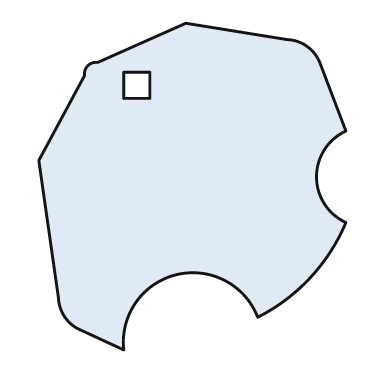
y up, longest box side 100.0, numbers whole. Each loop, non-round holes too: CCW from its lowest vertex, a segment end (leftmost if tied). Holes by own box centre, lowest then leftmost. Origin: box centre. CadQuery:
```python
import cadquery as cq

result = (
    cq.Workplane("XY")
    .moveTo(-21.0, -50.0)
    .threePointArc((-5.0, -27.0), (20.0, -40.0))
    .threePointArc((36.0, -28.0), (47.0, -11.0))
    .threePointArc((38.0, 3.0), (47.0, 17.0))
    .lineTo(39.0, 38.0)
    .threePointArc((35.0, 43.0), (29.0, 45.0))
    .lineTo(-2.0, 50.0)
    .lineTo(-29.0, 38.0)
    .threePointArc((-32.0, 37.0), (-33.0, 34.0))
    .lineTo(-47.0, 8.0)
    .lineTo(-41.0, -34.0)
    .threePointArc((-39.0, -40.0), (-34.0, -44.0))
    .close()
    .moveTo(-21.0, 27.0)
    .lineTo(-13.0, 27.0)
    .lineTo(-13.0, 35.0)
    .lineTo(-21.0, 35.0)
    .close()
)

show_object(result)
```